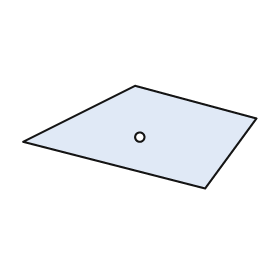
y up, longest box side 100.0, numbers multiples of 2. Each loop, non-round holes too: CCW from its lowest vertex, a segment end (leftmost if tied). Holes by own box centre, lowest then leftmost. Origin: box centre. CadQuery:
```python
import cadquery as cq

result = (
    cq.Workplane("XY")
    .moveTo(28.0, -22.0)
    .lineTo(50.0, 8.0)
    .lineTo(-2.0, 22.0)
    .lineTo(-50.0, -2.0)
    .close()
    .moveTo(0.0, 0.0)
    .circle(2.0)
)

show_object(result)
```